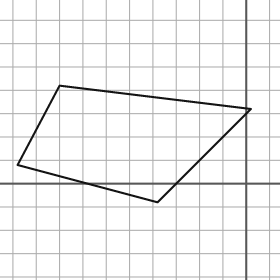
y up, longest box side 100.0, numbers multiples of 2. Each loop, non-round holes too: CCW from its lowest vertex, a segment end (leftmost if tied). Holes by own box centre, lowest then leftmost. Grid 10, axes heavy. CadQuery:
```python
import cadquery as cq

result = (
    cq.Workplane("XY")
    .moveTo(-38.0, -8.0)
    .lineTo(2.0, 32.0)
    .lineTo(-80.0, 42.0)
    .lineTo(-98.0, 8.0)
    .close()
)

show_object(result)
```